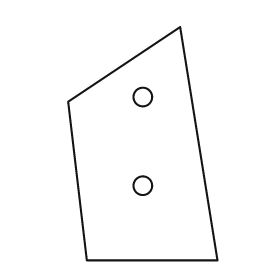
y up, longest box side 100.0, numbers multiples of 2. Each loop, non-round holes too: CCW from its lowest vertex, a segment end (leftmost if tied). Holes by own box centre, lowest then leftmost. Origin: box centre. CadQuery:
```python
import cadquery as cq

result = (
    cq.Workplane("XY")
    .moveTo(-24.0, -50.0)
    .lineTo(32.0, -50.0)
    .lineTo(16.0, 50.0)
    .lineTo(-32.0, 18.0)
    .close()
    .moveTo(0.0, -18.0)
    .circle(4.0)
    .moveTo(0.0, 20.0)
    .circle(4.0)
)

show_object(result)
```